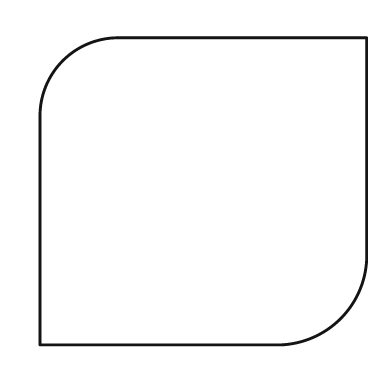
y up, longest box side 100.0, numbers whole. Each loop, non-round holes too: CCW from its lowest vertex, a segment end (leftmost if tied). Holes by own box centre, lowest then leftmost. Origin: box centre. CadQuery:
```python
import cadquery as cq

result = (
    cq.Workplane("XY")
    .moveTo(-50.0, -47.0)
    .lineTo(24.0, -47.0)
    .threePointArc((42.0, -39.0), (50.0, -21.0))
    .lineTo(50.0, 47.0)
    .lineTo(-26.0, 47.0)
    .threePointArc((-43.0, 40.0), (-50.0, 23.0))
    .close()
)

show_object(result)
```